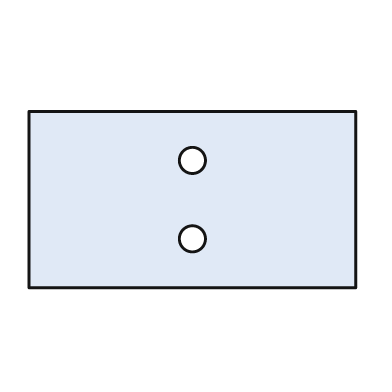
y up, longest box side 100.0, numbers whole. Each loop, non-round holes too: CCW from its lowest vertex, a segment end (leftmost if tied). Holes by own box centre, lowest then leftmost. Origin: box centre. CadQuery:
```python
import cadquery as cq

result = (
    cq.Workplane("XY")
    .moveTo(-50.0, -27.0)
    .lineTo(50.0, -27.0)
    .lineTo(50.0, 27.0)
    .lineTo(-50.0, 27.0)
    .close()
    .moveTo(0.0, -12.0)
    .circle(4.0)
    .moveTo(0.0, 12.0)
    .circle(4.0)
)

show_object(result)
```